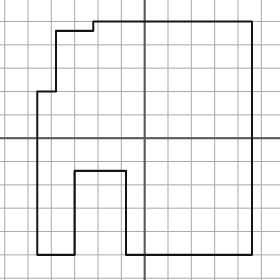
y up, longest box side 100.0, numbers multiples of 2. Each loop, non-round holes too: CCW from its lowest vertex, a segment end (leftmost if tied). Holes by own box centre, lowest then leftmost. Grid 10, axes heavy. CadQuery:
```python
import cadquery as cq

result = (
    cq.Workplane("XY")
    .moveTo(-46.0, -50.0)
    .lineTo(-30.0, -50.0)
    .lineTo(-30.0, -14.0)
    .lineTo(-8.0, -14.0)
    .lineTo(-8.0, -50.0)
    .lineTo(46.0, -50.0)
    .lineTo(46.0, 50.0)
    .lineTo(-22.0, 50.0)
    .lineTo(-22.0, 46.0)
    .lineTo(-38.0, 46.0)
    .lineTo(-38.0, 20.0)
    .lineTo(-46.0, 20.0)
    .close()
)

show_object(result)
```